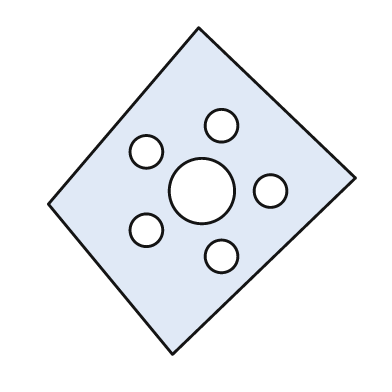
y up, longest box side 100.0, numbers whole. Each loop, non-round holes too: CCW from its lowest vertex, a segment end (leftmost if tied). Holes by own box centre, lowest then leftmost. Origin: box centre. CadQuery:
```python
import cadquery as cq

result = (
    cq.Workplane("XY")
    .moveTo(-9.0, -50.0)
    .lineTo(47.0, 4.0)
    .lineTo(-1.0, 50.0)
    .lineTo(-47.0, -4.0)
    .close()
    .moveTo(6.0, -20.0)
    .circle(5.0)
    .moveTo(-17.0, -12.0)
    .circle(5.0)
    .moveTo(0.0, 0.0)
    .circle(10.0)
    .moveTo(21.0, 0.0)
    .circle(5.0)
    .moveTo(-17.0, 12.0)
    .circle(5.0)
    .moveTo(6.0, 20.0)
    .circle(5.0)
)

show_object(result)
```